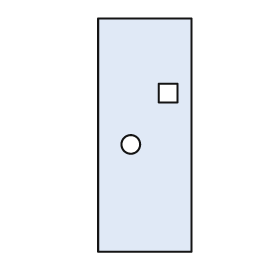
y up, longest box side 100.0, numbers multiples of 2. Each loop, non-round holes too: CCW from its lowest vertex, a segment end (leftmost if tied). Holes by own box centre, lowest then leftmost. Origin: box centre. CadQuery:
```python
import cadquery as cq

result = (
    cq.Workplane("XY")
    .moveTo(-20.0, -50.0)
    .lineTo(20.0, -50.0)
    .lineTo(20.0, 50.0)
    .lineTo(-20.0, 50.0)
    .close()
    .moveTo(-6.0, -4.0)
    .circle(4.0)
    .moveTo(6.0, 14.0)
    .lineTo(14.0, 14.0)
    .lineTo(14.0, 22.0)
    .lineTo(6.0, 22.0)
    .close()
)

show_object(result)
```